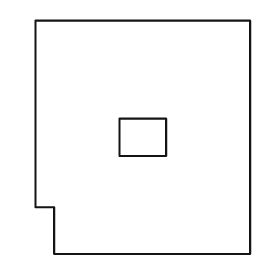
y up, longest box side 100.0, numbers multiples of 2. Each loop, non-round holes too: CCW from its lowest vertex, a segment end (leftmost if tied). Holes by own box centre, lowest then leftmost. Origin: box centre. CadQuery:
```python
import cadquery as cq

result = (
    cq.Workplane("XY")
    .moveTo(-38.0, -50.0)
    .lineTo(46.0, -50.0)
    .lineTo(46.0, 50.0)
    .lineTo(-46.0, 50.0)
    .lineTo(-46.0, -30.0)
    .lineTo(-38.0, -30.0)
    .close()
    .moveTo(-10.0, -8.0)
    .lineTo(10.0, -8.0)
    .lineTo(10.0, 8.0)
    .lineTo(-10.0, 8.0)
    .close()
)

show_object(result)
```